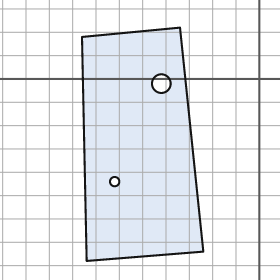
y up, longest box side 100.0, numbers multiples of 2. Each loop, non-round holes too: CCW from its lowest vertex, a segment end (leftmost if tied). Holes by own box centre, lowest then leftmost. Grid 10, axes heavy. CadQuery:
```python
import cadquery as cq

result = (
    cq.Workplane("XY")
    .moveTo(-74.0, -78.0)
    .lineTo(-24.0, -74.0)
    .lineTo(-34.0, 22.0)
    .lineTo(-76.0, 18.0)
    .close()
    .moveTo(-62.0, -44.0)
    .circle(2.0)
    .moveTo(-42.0, -2.0)
    .circle(4.0)
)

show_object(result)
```